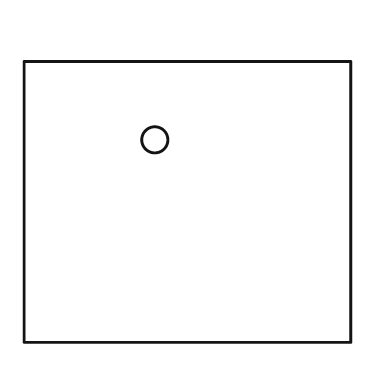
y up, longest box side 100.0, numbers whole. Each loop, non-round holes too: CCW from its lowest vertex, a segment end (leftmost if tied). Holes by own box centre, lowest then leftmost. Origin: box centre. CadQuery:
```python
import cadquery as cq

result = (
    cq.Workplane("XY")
    .moveTo(-50.0, -43.0)
    .lineTo(50.0, -43.0)
    .lineTo(50.0, 43.0)
    .lineTo(-50.0, 43.0)
    .close()
    .moveTo(-10.0, 19.0)
    .circle(4.0)
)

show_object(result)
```